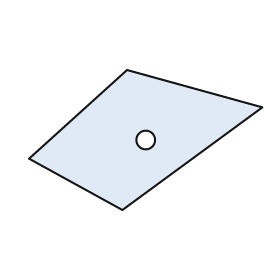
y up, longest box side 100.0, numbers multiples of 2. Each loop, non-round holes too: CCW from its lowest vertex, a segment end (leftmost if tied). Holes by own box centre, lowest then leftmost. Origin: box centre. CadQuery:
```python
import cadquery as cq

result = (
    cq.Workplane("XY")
    .moveTo(-10.0, -30.0)
    .lineTo(50.0, 14.0)
    .lineTo(-8.0, 30.0)
    .lineTo(-50.0, -8.0)
    .close()
    .moveTo(0.0, 0.0)
    .circle(4.0)
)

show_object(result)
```